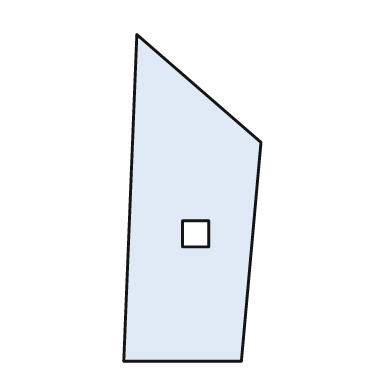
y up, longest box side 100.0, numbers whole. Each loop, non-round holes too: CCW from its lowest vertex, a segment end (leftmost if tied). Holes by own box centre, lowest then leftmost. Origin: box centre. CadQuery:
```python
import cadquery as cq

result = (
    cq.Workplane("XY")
    .moveTo(-21.0, -50.0)
    .lineTo(15.0, -50.0)
    .lineTo(21.0, 17.0)
    .lineTo(-17.0, 50.0)
    .close()
    .moveTo(-3.0, -15.0)
    .lineTo(5.0, -15.0)
    .lineTo(5.0, -7.0)
    .lineTo(-3.0, -7.0)
    .close()
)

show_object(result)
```